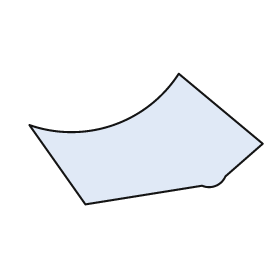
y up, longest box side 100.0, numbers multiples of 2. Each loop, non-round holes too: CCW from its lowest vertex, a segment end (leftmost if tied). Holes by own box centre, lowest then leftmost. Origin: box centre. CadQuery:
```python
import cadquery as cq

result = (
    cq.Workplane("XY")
    .moveTo(-26.0, -28.0)
    .lineTo(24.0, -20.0)
    .threePointArc((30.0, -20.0), (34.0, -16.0))
    .lineTo(50.0, -2.0)
    .lineTo(14.0, 28.0)
    .threePointArc((-14.0, 6.0), (-50.0, 6.0))
    .close()
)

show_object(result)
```